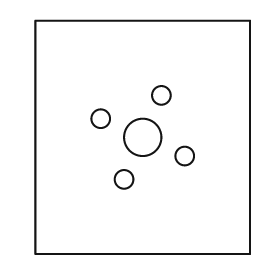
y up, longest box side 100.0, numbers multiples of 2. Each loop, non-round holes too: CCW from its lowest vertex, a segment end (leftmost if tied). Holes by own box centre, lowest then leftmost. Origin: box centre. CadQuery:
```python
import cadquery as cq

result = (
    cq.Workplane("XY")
    .moveTo(-46.0, -50.0)
    .lineTo(46.0, -50.0)
    .lineTo(46.0, 50.0)
    .lineTo(-46.0, 50.0)
    .close()
    .moveTo(-8.0, -18.0)
    .circle(4.0)
    .moveTo(18.0, -8.0)
    .circle(4.0)
    .moveTo(0.0, 0.0)
    .circle(8.0)
    .moveTo(-18.0, 8.0)
    .circle(4.0)
    .moveTo(8.0, 18.0)
    .circle(4.0)
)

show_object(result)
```